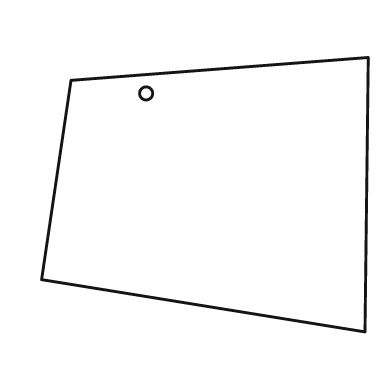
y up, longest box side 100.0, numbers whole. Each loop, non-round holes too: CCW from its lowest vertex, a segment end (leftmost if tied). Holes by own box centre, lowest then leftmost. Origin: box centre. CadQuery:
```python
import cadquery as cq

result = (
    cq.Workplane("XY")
    .moveTo(49.0, -42.0)
    .lineTo(50.0, 42.0)
    .lineTo(-41.0, 35.0)
    .lineTo(-50.0, -26.0)
    .close()
    .moveTo(-18.0, 31.0)
    .circle(2.0)
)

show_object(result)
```